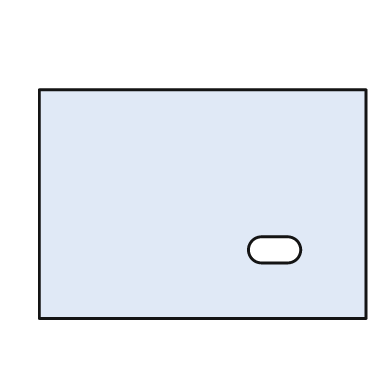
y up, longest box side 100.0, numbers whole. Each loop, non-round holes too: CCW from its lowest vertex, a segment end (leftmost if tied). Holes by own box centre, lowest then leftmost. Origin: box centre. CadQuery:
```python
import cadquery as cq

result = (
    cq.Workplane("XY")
    .moveTo(-50.0, -35.0)
    .lineTo(50.0, -35.0)
    .lineTo(50.0, 35.0)
    .lineTo(-50.0, 35.0)
    .close()
    .moveTo(18.0, -18.0)
    .lineTo(26.0, -18.0)
    .threePointArc((30.0, -14.0), (26.0, -10.0))
    .lineTo(18.0, -10.0)
    .threePointArc((14.0, -14.0), (18.0, -18.0))
    .close()
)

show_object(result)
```